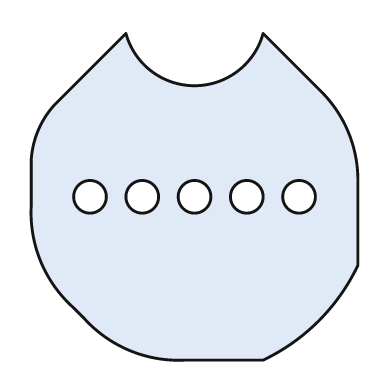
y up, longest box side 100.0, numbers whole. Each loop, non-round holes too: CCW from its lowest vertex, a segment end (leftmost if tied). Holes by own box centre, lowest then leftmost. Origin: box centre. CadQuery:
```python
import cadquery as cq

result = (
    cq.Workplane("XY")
    .moveTo(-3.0, -50.0)
    .lineTo(21.0, -50.0)
    .threePointArc((38.0, -38.0), (50.0, -21.0))
    .lineTo(50.0, 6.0)
    .threePointArc((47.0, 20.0), (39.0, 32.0))
    .lineTo(21.0, 50.0)
    .threePointArc((0.0, 34.0), (-21.0, 50.0))
    .lineTo(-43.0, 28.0)
    .threePointArc((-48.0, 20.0), (-50.0, 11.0))
    .lineTo(-50.0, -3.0)
    .threePointArc((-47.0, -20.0), (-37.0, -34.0))
    .lineTo(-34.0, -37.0)
    .threePointArc((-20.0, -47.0), (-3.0, -50.0))
    .close()
    .moveTo(-32.0, 0.0)
    .circle(5.0)
    .moveTo(-16.0, 0.0)
    .circle(5.0)
    .moveTo(0.0, 0.0)
    .circle(5.0)
    .moveTo(16.0, 0.0)
    .circle(5.0)
    .moveTo(32.0, 0.0)
    .circle(5.0)
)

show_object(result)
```